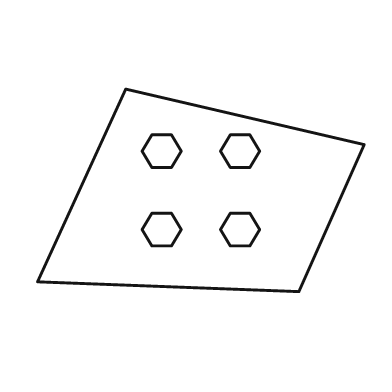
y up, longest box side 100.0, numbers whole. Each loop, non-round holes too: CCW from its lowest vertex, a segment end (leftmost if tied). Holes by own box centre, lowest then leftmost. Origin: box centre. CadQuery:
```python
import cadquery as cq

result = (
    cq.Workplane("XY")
    .moveTo(30.0, -31.0)
    .lineTo(50.0, 14.0)
    .lineTo(-23.0, 31.0)
    .lineTo(-50.0, -28.0)
    .close()
    .moveTo(-15.0, -17.0)
    .lineTo(-9.0, -17.0)
    .lineTo(-6.0, -12.0)
    .lineTo(-9.0, -7.0)
    .lineTo(-15.0, -7.0)
    .lineTo(-18.0, -12.0)
    .close()
    .moveTo(9.0, -17.0)
    .lineTo(15.0, -17.0)
    .lineTo(18.0, -12.0)
    .lineTo(15.0, -7.0)
    .lineTo(9.0, -7.0)
    .lineTo(6.0, -12.0)
    .close()
    .moveTo(-15.0, 7.0)
    .lineTo(-9.0, 7.0)
    .lineTo(-6.0, 12.0)
    .lineTo(-9.0, 17.0)
    .lineTo(-15.0, 17.0)
    .lineTo(-18.0, 12.0)
    .close()
    .moveTo(9.0, 7.0)
    .lineTo(15.0, 7.0)
    .lineTo(18.0, 12.0)
    .lineTo(15.0, 17.0)
    .lineTo(9.0, 17.0)
    .lineTo(6.0, 12.0)
    .close()
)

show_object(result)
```